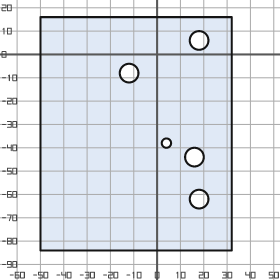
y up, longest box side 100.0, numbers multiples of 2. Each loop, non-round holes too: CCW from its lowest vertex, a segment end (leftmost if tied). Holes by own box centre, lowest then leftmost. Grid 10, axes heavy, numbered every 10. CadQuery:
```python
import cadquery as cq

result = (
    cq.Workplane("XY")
    .moveTo(-50.0, -84.0)
    .lineTo(32.0, -84.0)
    .lineTo(32.0, 16.0)
    .lineTo(-50.0, 16.0)
    .close()
    .moveTo(18.0, -62.0)
    .circle(4.0)
    .moveTo(16.0, -44.0)
    .circle(4.0)
    .moveTo(4.0, -38.0)
    .circle(2.0)
    .moveTo(-12.0, -8.0)
    .circle(4.0)
    .moveTo(18.0, 6.0)
    .circle(4.0)
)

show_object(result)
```